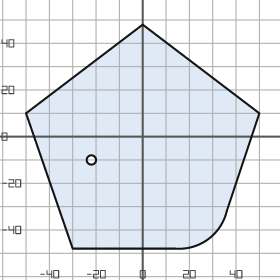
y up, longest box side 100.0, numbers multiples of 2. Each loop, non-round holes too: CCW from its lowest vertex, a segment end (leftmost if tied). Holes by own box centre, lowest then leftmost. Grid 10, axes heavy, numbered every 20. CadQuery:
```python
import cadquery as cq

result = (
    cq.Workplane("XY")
    .moveTo(-30.0, -48.0)
    .lineTo(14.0, -48.0)
    .threePointArc((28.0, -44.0), (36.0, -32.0))
    .lineTo(50.0, 10.0)
    .lineTo(0.0, 48.0)
    .lineTo(-50.0, 10.0)
    .close()
    .moveTo(-22.0, -10.0)
    .circle(2.0)
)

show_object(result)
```